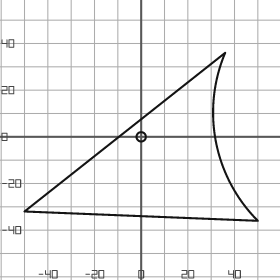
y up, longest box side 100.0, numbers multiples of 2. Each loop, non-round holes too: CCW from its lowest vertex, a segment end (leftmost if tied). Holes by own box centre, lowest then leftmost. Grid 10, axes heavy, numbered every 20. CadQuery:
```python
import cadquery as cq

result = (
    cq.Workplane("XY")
    .moveTo(50.0, -36.0)
    .threePointArc((32.0, -2.0), (36.0, 36.0))
    .lineTo(-50.0, -32.0)
    .close()
    .moveTo(0.0, 0.0)
    .circle(2.0)
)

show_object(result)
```